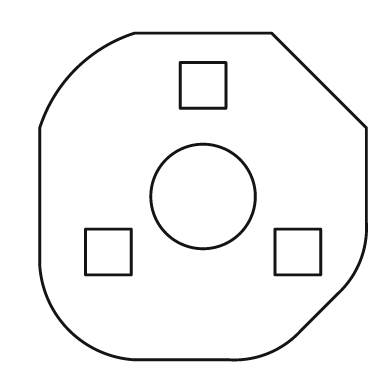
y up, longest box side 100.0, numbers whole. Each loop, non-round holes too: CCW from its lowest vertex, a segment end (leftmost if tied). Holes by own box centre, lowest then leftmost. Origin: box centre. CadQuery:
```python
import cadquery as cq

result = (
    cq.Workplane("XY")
    .moveTo(-21.0, -50.0)
    .lineTo(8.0, -50.0)
    .threePointArc((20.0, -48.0), (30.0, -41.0))
    .lineTo(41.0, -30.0)
    .threePointArc((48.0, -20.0), (50.0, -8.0))
    .lineTo(50.0, 21.0)
    .lineTo(21.0, 50.0)
    .lineTo(-21.0, 50.0)
    .threePointArc((-39.0, 39.0), (-50.0, 21.0))
    .lineTo(-50.0, -21.0)
    .threePointArc((-41.0, -41.0), (-21.0, -50.0))
    .close()
    .moveTo(-36.0, -24.0)
    .lineTo(-22.0, -24.0)
    .lineTo(-22.0, -10.0)
    .lineTo(-36.0, -10.0)
    .close()
    .moveTo(22.0, -24.0)
    .lineTo(36.0, -24.0)
    .lineTo(36.0, -10.0)
    .lineTo(22.0, -10.0)
    .close()
    .moveTo(0.0, 0.0)
    .circle(16.0)
    .moveTo(-7.0, 27.0)
    .lineTo(7.0, 27.0)
    .lineTo(7.0, 41.0)
    .lineTo(-7.0, 41.0)
    .close()
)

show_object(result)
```